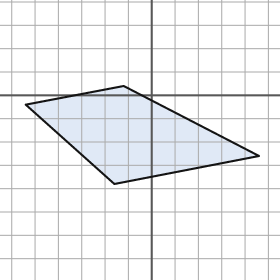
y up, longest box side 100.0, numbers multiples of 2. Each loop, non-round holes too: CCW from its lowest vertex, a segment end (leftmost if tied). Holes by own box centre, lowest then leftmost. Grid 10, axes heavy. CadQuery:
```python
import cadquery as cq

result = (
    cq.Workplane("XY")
    .moveTo(-16.0, -38.0)
    .lineTo(46.0, -26.0)
    .lineTo(-12.0, 4.0)
    .lineTo(-54.0, -4.0)
    .close()
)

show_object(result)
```